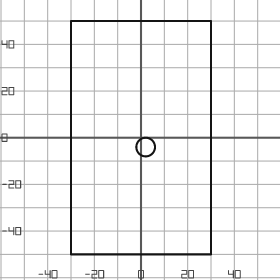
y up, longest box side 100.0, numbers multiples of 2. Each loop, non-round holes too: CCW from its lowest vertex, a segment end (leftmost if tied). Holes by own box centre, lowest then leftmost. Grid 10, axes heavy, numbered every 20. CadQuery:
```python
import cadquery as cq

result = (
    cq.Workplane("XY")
    .moveTo(-30.0, -50.0)
    .lineTo(30.0, -50.0)
    .lineTo(30.0, 50.0)
    .lineTo(-30.0, 50.0)
    .close()
    .moveTo(2.0, -4.0)
    .circle(4.0)
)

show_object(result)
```